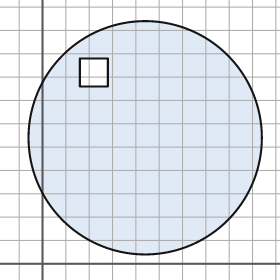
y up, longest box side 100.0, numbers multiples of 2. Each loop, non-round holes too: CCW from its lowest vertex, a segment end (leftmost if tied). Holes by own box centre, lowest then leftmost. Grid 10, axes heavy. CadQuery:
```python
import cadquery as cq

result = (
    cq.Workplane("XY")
    .moveTo(44.0, 54.0)
    .circle(50.0)
    .moveTo(16.0, 76.0)
    .lineTo(28.0, 76.0)
    .lineTo(28.0, 88.0)
    .lineTo(16.0, 88.0)
    .close()
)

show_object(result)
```